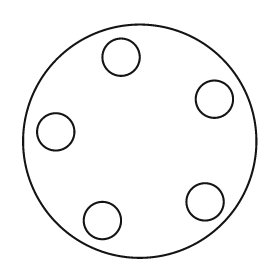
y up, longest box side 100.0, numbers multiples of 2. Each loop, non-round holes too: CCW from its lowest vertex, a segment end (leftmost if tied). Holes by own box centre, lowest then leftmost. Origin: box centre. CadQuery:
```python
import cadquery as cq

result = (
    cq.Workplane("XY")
    .moveTo(0.0, 0.0)
    .circle(50.0)
    .moveTo(-16.0, -34.0)
    .circle(8.0)
    .moveTo(28.0, -26.0)
    .circle(8.0)
    .moveTo(-36.0, 4.0)
    .circle(8.0)
    .moveTo(32.0, 18.0)
    .circle(8.0)
    .moveTo(-8.0, 36.0)
    .circle(8.0)
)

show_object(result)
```